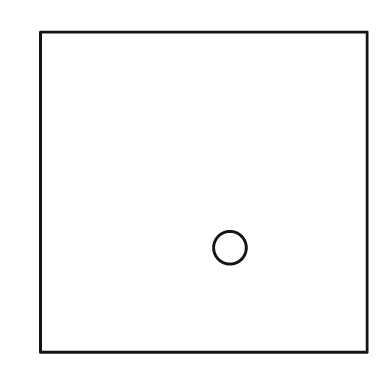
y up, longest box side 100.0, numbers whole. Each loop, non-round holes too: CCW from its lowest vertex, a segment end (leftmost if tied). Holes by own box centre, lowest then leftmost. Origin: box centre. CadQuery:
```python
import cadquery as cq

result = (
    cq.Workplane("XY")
    .moveTo(-50.0, -49.0)
    .lineTo(50.0, -49.0)
    .lineTo(50.0, 49.0)
    .lineTo(-50.0, 49.0)
    .close()
    .moveTo(8.0, -17.0)
    .circle(5.0)
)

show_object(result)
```